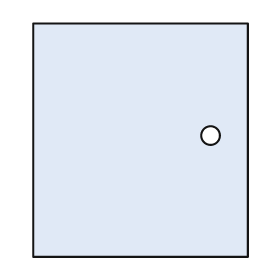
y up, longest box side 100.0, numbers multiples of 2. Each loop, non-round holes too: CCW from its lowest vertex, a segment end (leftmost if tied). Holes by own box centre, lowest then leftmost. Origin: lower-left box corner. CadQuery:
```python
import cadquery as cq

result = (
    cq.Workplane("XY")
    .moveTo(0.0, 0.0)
    .lineTo(92.0, 0.0)
    .lineTo(92.0, 100.0)
    .lineTo(0.0, 100.0)
    .close()
    .moveTo(76.0, 52.0)
    .circle(4.0)
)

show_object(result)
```